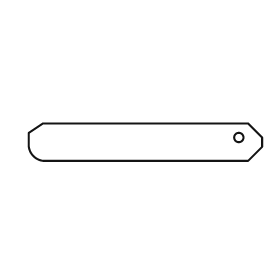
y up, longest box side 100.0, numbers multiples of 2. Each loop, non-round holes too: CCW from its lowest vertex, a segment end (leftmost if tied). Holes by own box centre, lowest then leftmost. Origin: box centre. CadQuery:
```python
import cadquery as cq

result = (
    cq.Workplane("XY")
    .moveTo(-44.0, -8.0)
    .lineTo(44.0, -8.0)
    .lineTo(50.0, -2.0)
    .lineTo(50.0, 2.0)
    .lineTo(44.0, 8.0)
    .lineTo(-44.0, 8.0)
    .lineTo(-50.0, 4.0)
    .lineTo(-50.0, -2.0)
    .threePointArc((-48.0, -6.0), (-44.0, -8.0))
    .close()
    .moveTo(40.0, 2.0)
    .circle(2.0)
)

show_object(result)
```